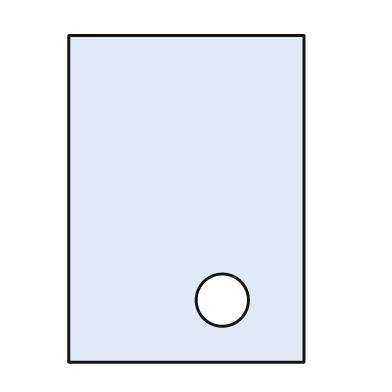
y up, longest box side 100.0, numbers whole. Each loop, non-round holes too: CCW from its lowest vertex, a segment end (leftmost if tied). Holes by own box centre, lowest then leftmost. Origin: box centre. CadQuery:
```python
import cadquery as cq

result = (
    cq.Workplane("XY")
    .moveTo(-36.0, -50.0)
    .lineTo(36.0, -50.0)
    .lineTo(36.0, 50.0)
    .lineTo(-36.0, 50.0)
    .close()
    .moveTo(11.0, -31.0)
    .circle(8.0)
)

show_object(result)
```